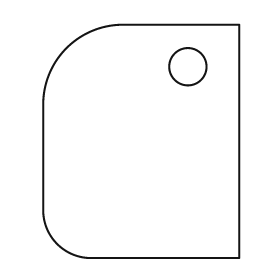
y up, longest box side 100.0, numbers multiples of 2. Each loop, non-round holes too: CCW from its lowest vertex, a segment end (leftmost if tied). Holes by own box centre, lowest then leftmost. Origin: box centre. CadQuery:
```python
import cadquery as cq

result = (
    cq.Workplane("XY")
    .moveTo(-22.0, -50.0)
    .lineTo(42.0, -50.0)
    .lineTo(42.0, 50.0)
    .lineTo(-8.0, 50.0)
    .threePointArc((-32.0, 40.0), (-42.0, 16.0))
    .lineTo(-42.0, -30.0)
    .threePointArc((-36.0, -44.0), (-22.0, -50.0))
    .close()
    .moveTo(20.0, 32.0)
    .circle(8.0)
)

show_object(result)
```